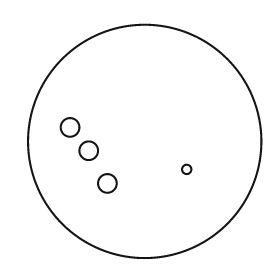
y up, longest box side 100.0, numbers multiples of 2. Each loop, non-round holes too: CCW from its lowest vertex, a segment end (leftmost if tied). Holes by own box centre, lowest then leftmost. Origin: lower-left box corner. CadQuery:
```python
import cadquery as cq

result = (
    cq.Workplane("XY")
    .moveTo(50.0, 50.0)
    .circle(50.0)
    .moveTo(34.0, 32.0)
    .circle(4.0)
    .moveTo(68.0, 38.0)
    .circle(2.0)
    .moveTo(26.0, 46.0)
    .circle(4.0)
    .moveTo(18.0, 56.0)
    .circle(4.0)
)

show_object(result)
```